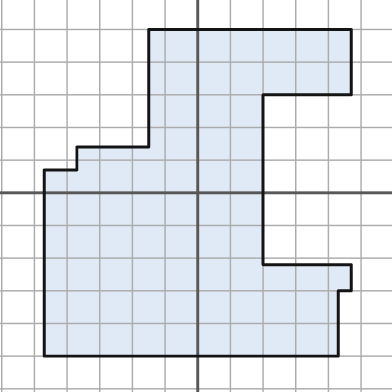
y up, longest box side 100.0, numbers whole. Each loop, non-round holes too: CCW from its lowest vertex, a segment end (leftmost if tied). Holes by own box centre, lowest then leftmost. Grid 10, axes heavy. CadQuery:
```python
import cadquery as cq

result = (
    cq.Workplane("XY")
    .moveTo(-47.0, -50.0)
    .lineTo(43.0, -50.0)
    .lineTo(43.0, -30.0)
    .lineTo(47.0, -30.0)
    .lineTo(47.0, -22.0)
    .lineTo(20.0, -22.0)
    .lineTo(20.0, 30.0)
    .lineTo(47.0, 30.0)
    .lineTo(47.0, 50.0)
    .lineTo(-15.0, 50.0)
    .lineTo(-15.0, 14.0)
    .lineTo(-37.0, 14.0)
    .lineTo(-37.0, 7.0)
    .lineTo(-47.0, 7.0)
    .close()
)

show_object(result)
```